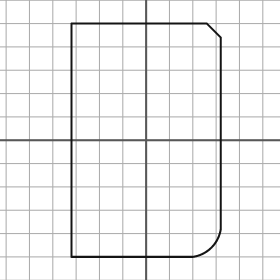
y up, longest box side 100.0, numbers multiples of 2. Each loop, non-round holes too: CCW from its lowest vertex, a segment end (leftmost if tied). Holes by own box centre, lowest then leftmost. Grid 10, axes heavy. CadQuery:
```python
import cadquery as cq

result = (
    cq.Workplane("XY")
    .moveTo(-32.0, -50.0)
    .lineTo(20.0, -50.0)
    .threePointArc((28.0, -46.0), (32.0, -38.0))
    .lineTo(32.0, 44.0)
    .lineTo(26.0, 50.0)
    .lineTo(-32.0, 50.0)
    .close()
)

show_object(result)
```